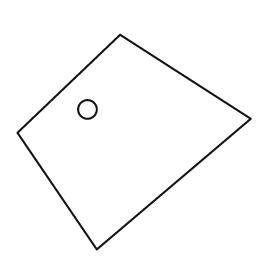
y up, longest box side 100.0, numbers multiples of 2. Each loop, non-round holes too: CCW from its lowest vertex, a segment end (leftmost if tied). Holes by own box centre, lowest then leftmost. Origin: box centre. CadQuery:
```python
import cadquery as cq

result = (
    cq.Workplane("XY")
    .moveTo(-16.0, -46.0)
    .lineTo(50.0, 10.0)
    .lineTo(-6.0, 46.0)
    .lineTo(-50.0, 4.0)
    .close()
    .moveTo(-20.0, 14.0)
    .circle(4.0)
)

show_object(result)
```